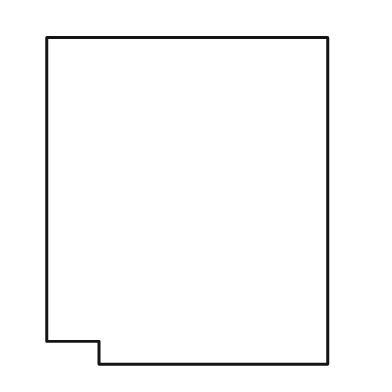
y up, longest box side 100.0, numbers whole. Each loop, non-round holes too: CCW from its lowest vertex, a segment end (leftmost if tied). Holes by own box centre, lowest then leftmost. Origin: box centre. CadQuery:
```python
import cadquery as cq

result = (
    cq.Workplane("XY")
    .moveTo(-27.0, -50.0)
    .lineTo(43.0, -50.0)
    .lineTo(43.0, 50.0)
    .lineTo(-43.0, 50.0)
    .lineTo(-43.0, -43.0)
    .lineTo(-27.0, -43.0)
    .close()
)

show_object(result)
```